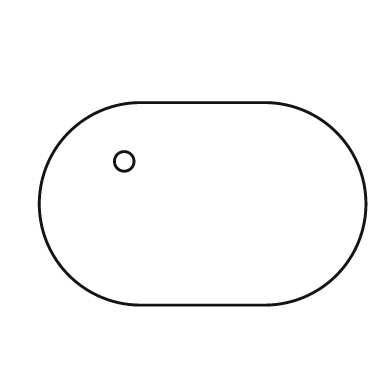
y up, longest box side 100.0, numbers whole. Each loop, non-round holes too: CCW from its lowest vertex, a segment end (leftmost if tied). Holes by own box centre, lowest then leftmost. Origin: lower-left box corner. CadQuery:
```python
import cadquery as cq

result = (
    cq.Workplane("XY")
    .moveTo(31.0, 0.0)
    .lineTo(69.0, 0.0)
    .threePointArc((100.0, 31.0), (69.0, 62.0))
    .lineTo(31.0, 62.0)
    .threePointArc((0.0, 31.0), (31.0, 0.0))
    .close()
    .moveTo(26.0, 44.0)
    .circle(3.0)
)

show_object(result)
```